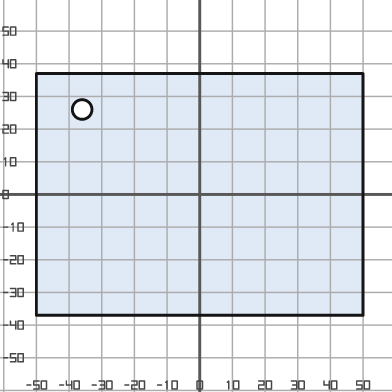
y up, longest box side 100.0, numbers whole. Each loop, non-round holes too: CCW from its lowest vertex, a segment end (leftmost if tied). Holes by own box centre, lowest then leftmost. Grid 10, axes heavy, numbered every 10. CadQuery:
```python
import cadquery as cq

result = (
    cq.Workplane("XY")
    .moveTo(-50.0, -37.0)
    .lineTo(50.0, -37.0)
    .lineTo(50.0, 37.0)
    .lineTo(-50.0, 37.0)
    .close()
    .moveTo(-36.0, 26.0)
    .circle(3.0)
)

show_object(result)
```